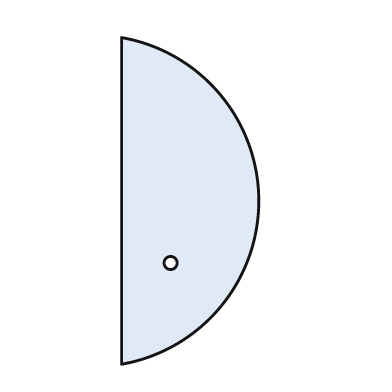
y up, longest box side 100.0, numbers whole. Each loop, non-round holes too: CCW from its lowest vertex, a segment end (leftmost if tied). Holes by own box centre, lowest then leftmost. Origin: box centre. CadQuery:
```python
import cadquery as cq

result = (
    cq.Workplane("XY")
    .moveTo(-21.0, -50.0)
    .threePointArc((21.0, 0.0), (-21.0, 50.0))
    .close()
    .moveTo(-6.0, -19.0)
    .circle(2.0)
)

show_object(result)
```